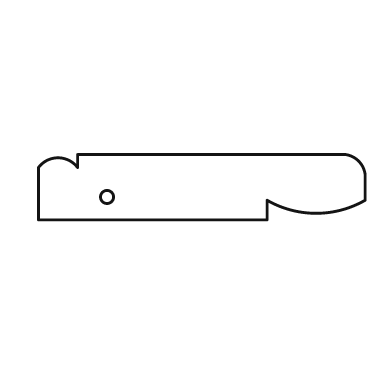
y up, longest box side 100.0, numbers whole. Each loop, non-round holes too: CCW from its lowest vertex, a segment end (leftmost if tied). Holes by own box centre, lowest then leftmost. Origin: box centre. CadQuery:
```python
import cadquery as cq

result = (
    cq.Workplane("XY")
    .moveTo(-50.0, -10.0)
    .lineTo(20.0, -10.0)
    .lineTo(20.0, -4.0)
    .threePointArc((35.0, -8.0), (50.0, -4.0))
    .lineTo(50.0, 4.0)
    .threePointArc((48.0, 8.0), (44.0, 10.0))
    .lineTo(-38.0, 10.0)
    .lineTo(-38.0, 6.0)
    .threePointArc((-44.0, 9.0), (-50.0, 6.0))
    .close()
    .moveTo(-29.0, -3.0)
    .circle(2.0)
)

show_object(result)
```